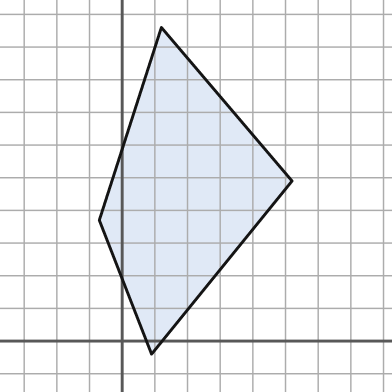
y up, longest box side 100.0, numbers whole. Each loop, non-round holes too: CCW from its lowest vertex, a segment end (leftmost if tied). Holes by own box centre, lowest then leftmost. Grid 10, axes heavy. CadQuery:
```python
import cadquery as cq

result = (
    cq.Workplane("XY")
    .moveTo(9.0, -4.0)
    .lineTo(52.0, 49.0)
    .lineTo(12.0, 96.0)
    .lineTo(-7.0, 37.0)
    .close()
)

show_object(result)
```